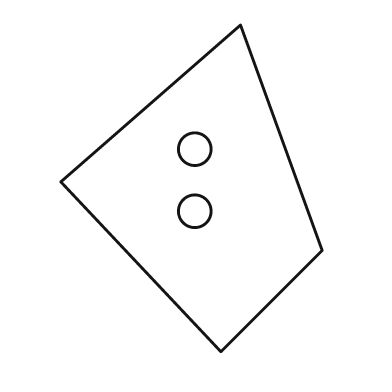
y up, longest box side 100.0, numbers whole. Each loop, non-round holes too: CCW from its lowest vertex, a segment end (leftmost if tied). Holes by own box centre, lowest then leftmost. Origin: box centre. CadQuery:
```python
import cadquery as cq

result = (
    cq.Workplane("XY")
    .moveTo(9.0, -50.0)
    .lineTo(40.0, -19.0)
    .lineTo(15.0, 50.0)
    .lineTo(-40.0, 2.0)
    .close()
    .moveTo(1.0, -7.0)
    .circle(5.0)
    .moveTo(1.0, 12.0)
    .circle(5.0)
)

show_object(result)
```